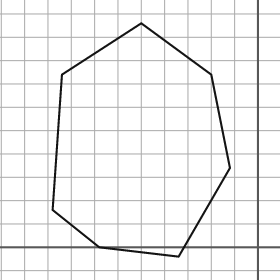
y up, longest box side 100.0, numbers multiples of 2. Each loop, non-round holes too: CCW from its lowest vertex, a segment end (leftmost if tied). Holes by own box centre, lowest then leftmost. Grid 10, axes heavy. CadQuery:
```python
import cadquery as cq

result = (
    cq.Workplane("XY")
    .moveTo(-34.0, -4.0)
    .lineTo(-12.0, 34.0)
    .lineTo(-20.0, 74.0)
    .lineTo(-50.0, 96.0)
    .lineTo(-84.0, 74.0)
    .lineTo(-88.0, 16.0)
    .lineTo(-68.0, 0.0)
    .close()
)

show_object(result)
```